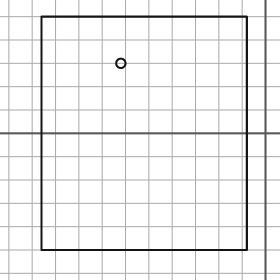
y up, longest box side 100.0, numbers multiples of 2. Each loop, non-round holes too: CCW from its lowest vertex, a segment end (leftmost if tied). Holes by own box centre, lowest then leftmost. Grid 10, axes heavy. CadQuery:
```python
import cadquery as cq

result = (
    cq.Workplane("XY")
    .moveTo(-96.0, -50.0)
    .lineTo(-8.0, -50.0)
    .lineTo(-8.0, 50.0)
    .lineTo(-96.0, 50.0)
    .close()
    .moveTo(-62.0, 30.0)
    .circle(2.0)
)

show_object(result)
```